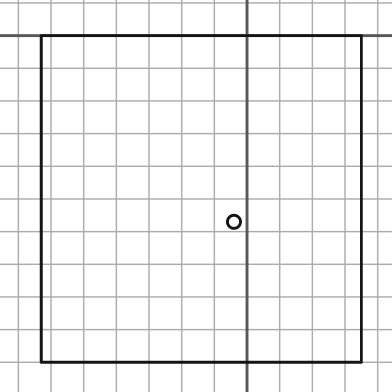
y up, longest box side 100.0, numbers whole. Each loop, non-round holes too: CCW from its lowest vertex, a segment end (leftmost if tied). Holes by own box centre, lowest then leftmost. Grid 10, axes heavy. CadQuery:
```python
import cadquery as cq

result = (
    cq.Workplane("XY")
    .moveTo(-63.0, -100.0)
    .lineTo(35.0, -100.0)
    .lineTo(35.0, 0.0)
    .lineTo(-63.0, 0.0)
    .close()
    .moveTo(-4.0, -57.0)
    .circle(2.0)
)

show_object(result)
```